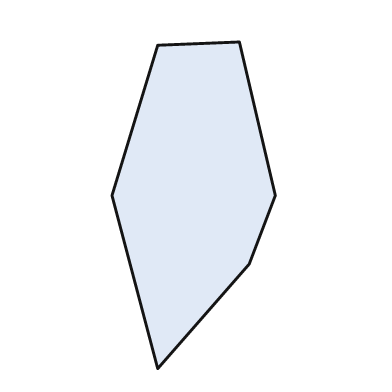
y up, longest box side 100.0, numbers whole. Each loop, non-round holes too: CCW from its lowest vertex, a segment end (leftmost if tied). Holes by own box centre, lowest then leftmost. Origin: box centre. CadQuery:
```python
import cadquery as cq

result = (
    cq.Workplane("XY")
    .moveTo(-11.0, -50.0)
    .lineTo(17.0, -18.0)
    .lineTo(25.0, 3.0)
    .lineTo(14.0, 50.0)
    .lineTo(-11.0, 49.0)
    .lineTo(-25.0, 3.0)
    .close()
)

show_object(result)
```